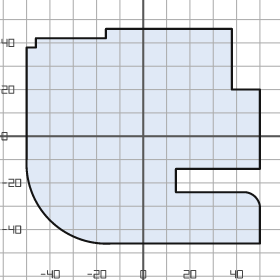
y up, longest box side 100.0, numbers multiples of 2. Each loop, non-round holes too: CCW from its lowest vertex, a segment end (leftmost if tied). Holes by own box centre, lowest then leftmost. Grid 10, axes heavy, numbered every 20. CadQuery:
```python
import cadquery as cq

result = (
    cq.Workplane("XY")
    .moveTo(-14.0, -46.0)
    .lineTo(50.0, -46.0)
    .lineTo(50.0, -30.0)
    .threePointArc((48.0, -26.0), (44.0, -24.0))
    .lineTo(14.0, -24.0)
    .lineTo(14.0, -14.0)
    .lineTo(50.0, -14.0)
    .lineTo(50.0, 20.0)
    .lineTo(38.0, 20.0)
    .lineTo(38.0, 46.0)
    .lineTo(-16.0, 46.0)
    .lineTo(-16.0, 42.0)
    .lineTo(-46.0, 42.0)
    .lineTo(-46.0, 38.0)
    .lineTo(-50.0, 38.0)
    .lineTo(-50.0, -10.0)
    .threePointArc((-40.0, -36.0), (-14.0, -46.0))
    .close()
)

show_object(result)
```